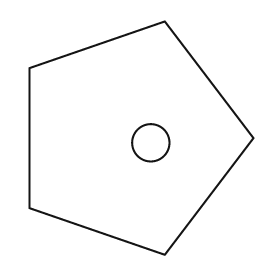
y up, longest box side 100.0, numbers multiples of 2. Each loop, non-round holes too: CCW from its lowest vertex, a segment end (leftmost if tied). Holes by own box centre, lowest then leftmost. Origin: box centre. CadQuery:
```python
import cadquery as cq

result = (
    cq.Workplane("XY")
    .moveTo(10.0, -50.0)
    .lineTo(48.0, 0.0)
    .lineTo(10.0, 50.0)
    .lineTo(-48.0, 30.0)
    .lineTo(-48.0, -30.0)
    .close()
    .moveTo(4.0, -2.0)
    .circle(8.0)
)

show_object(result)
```